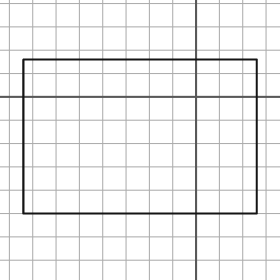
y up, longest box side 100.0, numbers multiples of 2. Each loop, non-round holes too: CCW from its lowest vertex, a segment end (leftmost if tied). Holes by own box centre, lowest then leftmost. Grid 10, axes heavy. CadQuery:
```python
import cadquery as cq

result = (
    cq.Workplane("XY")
    .moveTo(-74.0, -50.0)
    .lineTo(26.0, -50.0)
    .lineTo(26.0, 16.0)
    .lineTo(-74.0, 16.0)
    .close()
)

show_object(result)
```